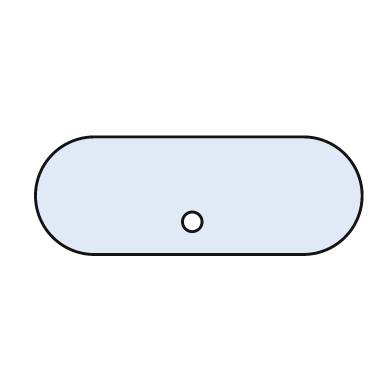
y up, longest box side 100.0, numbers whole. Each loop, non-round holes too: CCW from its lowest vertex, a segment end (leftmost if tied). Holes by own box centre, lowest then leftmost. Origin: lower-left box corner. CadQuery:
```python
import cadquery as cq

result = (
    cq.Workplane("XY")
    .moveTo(18.0, 0.0)
    .lineTo(82.0, 0.0)
    .threePointArc((100.0, 18.0), (82.0, 36.0))
    .lineTo(18.0, 36.0)
    .threePointArc((0.0, 18.0), (18.0, 0.0))
    .close()
    .moveTo(48.0, 10.0)
    .circle(3.0)
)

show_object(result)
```